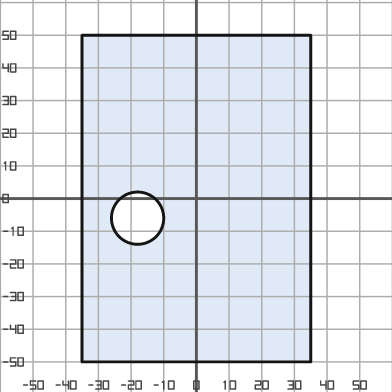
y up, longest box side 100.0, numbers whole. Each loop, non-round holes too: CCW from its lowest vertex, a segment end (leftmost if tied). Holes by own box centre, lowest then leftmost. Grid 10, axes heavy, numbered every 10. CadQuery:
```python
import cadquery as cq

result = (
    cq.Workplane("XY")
    .moveTo(-35.0, -50.0)
    .lineTo(35.0, -50.0)
    .lineTo(35.0, 50.0)
    .lineTo(-35.0, 50.0)
    .close()
    .moveTo(-18.0, -6.0)
    .circle(8.0)
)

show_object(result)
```